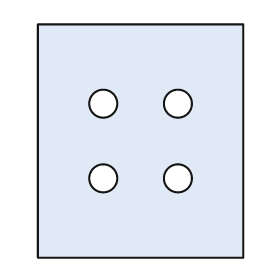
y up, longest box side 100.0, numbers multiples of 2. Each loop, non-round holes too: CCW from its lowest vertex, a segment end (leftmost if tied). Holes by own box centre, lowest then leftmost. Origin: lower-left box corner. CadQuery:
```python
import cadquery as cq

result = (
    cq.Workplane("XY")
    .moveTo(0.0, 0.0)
    .lineTo(88.0, 0.0)
    .lineTo(88.0, 100.0)
    .lineTo(0.0, 100.0)
    .close()
    .moveTo(28.0, 34.0)
    .circle(6.0)
    .moveTo(60.0, 34.0)
    .circle(6.0)
    .moveTo(28.0, 66.0)
    .circle(6.0)
    .moveTo(60.0, 66.0)
    .circle(6.0)
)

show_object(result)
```